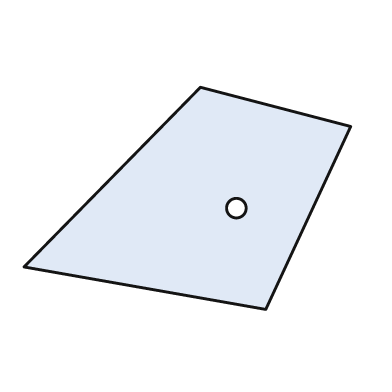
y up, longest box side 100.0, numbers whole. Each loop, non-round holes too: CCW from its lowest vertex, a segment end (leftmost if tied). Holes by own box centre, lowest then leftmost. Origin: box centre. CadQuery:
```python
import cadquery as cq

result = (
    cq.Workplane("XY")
    .moveTo(24.0, -34.0)
    .lineTo(50.0, 22.0)
    .lineTo(4.0, 34.0)
    .lineTo(-50.0, -21.0)
    .close()
    .moveTo(15.0, -3.0)
    .circle(3.0)
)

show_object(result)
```